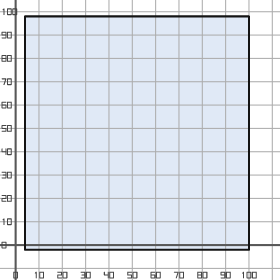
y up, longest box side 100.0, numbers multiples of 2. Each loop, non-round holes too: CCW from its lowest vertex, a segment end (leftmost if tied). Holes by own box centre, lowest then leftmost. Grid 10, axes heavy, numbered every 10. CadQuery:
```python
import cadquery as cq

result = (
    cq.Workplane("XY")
    .moveTo(4.0, -2.0)
    .lineTo(100.0, -2.0)
    .lineTo(100.0, 98.0)
    .lineTo(4.0, 98.0)
    .close()
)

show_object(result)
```